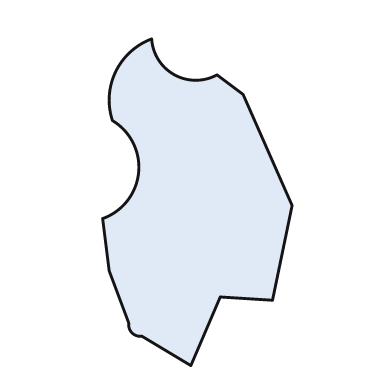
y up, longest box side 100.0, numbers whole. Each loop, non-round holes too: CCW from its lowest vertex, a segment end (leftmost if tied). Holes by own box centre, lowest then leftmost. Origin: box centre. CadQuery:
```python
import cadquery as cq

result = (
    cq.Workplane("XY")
    .moveTo(-2.0, -50.0)
    .lineTo(7.0, -29.0)
    .lineTo(23.0, -30.0)
    .lineTo(29.0, -1.0)
    .lineTo(14.0, 33.0)
    .lineTo(6.0, 39.0)
    .threePointArc((-7.0, 39.0), (-14.0, 50.0))
    .threePointArc((-25.0, 40.0), (-26.0, 25.0))
    .threePointArc((-18.0, 9.0), (-29.0, -5.0))
    .lineTo(-27.0, -21.0)
    .lineTo(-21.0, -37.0)
    .threePointArc((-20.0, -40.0), (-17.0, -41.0))
    .close()
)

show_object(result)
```